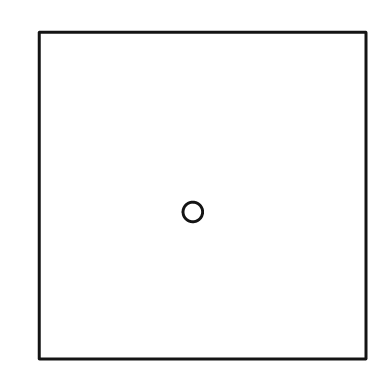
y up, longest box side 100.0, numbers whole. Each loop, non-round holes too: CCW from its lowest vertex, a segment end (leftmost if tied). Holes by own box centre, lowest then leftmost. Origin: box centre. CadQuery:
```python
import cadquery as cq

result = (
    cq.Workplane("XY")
    .moveTo(-50.0, -50.0)
    .lineTo(50.0, -50.0)
    .lineTo(50.0, 50.0)
    .lineTo(-50.0, 50.0)
    .close()
    .moveTo(-3.0, -5.0)
    .circle(3.0)
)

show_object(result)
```